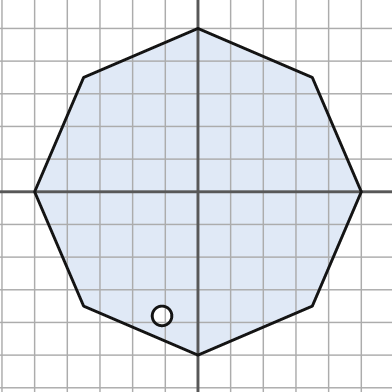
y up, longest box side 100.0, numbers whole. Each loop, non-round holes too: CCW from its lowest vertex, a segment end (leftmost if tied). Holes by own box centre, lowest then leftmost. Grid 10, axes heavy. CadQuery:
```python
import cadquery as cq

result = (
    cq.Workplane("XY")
    .moveTo(0.0, -50.0)
    .lineTo(35.0, -35.0)
    .lineTo(50.0, 0.0)
    .lineTo(35.0, 35.0)
    .lineTo(0.0, 50.0)
    .lineTo(-35.0, 35.0)
    .lineTo(-50.0, 0.0)
    .lineTo(-35.0, -35.0)
    .close()
    .moveTo(-11.0, -38.0)
    .circle(3.0)
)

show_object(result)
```